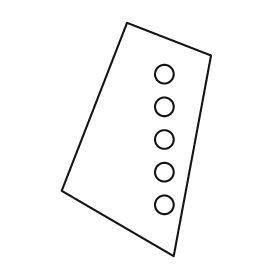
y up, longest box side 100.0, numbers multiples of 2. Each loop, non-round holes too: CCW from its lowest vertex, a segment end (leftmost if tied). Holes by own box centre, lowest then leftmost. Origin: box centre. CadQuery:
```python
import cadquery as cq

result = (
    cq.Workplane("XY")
    .moveTo(16.0, -50.0)
    .lineTo(32.0, 36.0)
    .lineTo(-4.0, 50.0)
    .lineTo(-32.0, -22.0)
    .close()
    .moveTo(12.0, -28.0)
    .circle(4.0)
    .moveTo(12.0, -14.0)
    .circle(4.0)
    .moveTo(12.0, 0.0)
    .circle(4.0)
    .moveTo(12.0, 14.0)
    .circle(4.0)
    .moveTo(12.0, 28.0)
    .circle(4.0)
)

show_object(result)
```